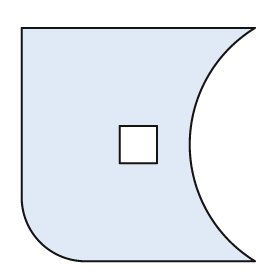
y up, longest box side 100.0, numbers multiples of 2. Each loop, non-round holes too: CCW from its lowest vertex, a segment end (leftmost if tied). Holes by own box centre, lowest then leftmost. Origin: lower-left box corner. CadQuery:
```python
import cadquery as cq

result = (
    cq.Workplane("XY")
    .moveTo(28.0, 0.0)
    .lineTo(100.0, 0.0)
    .threePointArc((72.0, 50.0), (100.0, 100.0))
    .lineTo(0.0, 100.0)
    .lineTo(0.0, 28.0)
    .threePointArc((8.0, 8.0), (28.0, 0.0))
    .close()
    .moveTo(42.0, 42.0)
    .lineTo(58.0, 42.0)
    .lineTo(58.0, 58.0)
    .lineTo(42.0, 58.0)
    .close()
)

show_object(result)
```